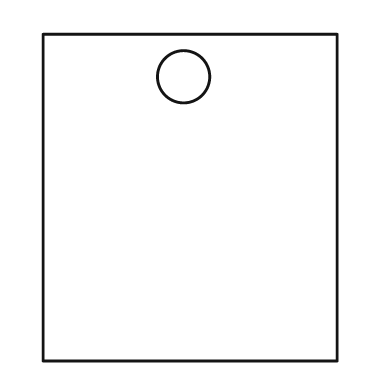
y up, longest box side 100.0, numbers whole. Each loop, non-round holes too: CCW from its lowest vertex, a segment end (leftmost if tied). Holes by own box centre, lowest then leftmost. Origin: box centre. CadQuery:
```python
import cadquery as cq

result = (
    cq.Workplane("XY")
    .moveTo(-45.0, -50.0)
    .lineTo(45.0, -50.0)
    .lineTo(45.0, 50.0)
    .lineTo(-45.0, 50.0)
    .close()
    .moveTo(-2.0, 37.0)
    .circle(8.0)
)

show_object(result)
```